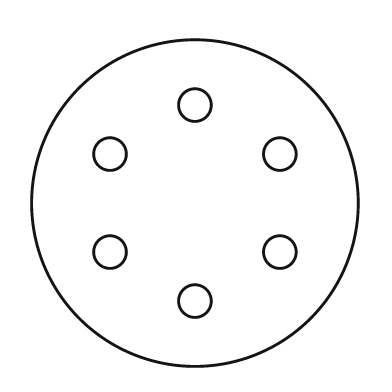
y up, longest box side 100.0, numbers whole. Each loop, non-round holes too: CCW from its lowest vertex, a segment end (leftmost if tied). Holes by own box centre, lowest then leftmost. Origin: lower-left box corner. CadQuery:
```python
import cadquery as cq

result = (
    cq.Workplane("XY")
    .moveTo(50.0, 50.0)
    .circle(50.0)
    .moveTo(50.0, 20.0)
    .circle(5.0)
    .moveTo(24.0, 35.0)
    .circle(5.0)
    .moveTo(76.0, 35.0)
    .circle(5.0)
    .moveTo(24.0, 65.0)
    .circle(5.0)
    .moveTo(76.0, 65.0)
    .circle(5.0)
    .moveTo(50.0, 80.0)
    .circle(5.0)
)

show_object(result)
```